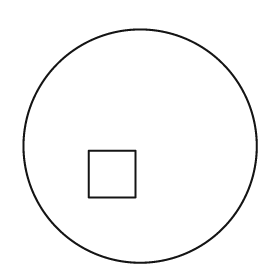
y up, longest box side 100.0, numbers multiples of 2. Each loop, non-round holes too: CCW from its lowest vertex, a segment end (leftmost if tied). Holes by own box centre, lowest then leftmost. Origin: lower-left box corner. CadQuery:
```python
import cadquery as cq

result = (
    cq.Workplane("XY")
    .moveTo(50.0, 50.0)
    .circle(50.0)
    .moveTo(28.0, 28.0)
    .lineTo(48.0, 28.0)
    .lineTo(48.0, 48.0)
    .lineTo(28.0, 48.0)
    .close()
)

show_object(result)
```